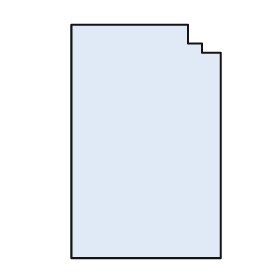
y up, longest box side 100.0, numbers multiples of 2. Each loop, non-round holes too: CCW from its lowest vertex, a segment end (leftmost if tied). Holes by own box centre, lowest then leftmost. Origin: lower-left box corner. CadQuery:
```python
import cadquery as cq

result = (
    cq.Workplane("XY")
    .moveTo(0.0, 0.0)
    .lineTo(64.0, 0.0)
    .lineTo(64.0, 88.0)
    .lineTo(56.0, 88.0)
    .lineTo(56.0, 92.0)
    .lineTo(50.0, 92.0)
    .lineTo(50.0, 100.0)
    .lineTo(0.0, 100.0)
    .close()
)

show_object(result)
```